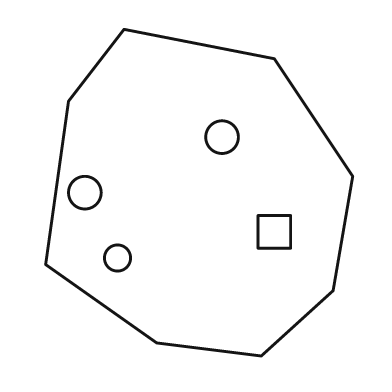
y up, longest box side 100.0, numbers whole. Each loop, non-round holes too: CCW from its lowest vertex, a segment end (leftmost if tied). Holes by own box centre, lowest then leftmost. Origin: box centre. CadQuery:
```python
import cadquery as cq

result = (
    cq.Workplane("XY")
    .moveTo(19.0, -50.0)
    .lineTo(41.0, -30.0)
    .lineTo(47.0, 5.0)
    .lineTo(23.0, 41.0)
    .lineTo(-23.0, 50.0)
    .lineTo(-40.0, 28.0)
    .lineTo(-47.0, -22.0)
    .lineTo(-13.0, -46.0)
    .close()
    .moveTo(-25.0, -20.0)
    .circle(4.0)
    .moveTo(18.0, -17.0)
    .lineTo(28.0, -17.0)
    .lineTo(28.0, -7.0)
    .lineTo(18.0, -7.0)
    .close()
    .moveTo(-35.0, 0.0)
    .circle(5.0)
    .moveTo(7.0, 17.0)
    .circle(5.0)
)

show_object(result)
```